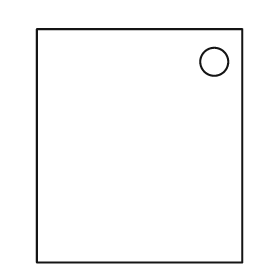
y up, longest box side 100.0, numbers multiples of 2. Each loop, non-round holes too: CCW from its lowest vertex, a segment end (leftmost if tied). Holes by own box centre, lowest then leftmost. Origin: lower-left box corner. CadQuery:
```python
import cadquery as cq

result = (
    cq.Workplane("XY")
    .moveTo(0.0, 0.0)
    .lineTo(88.0, 0.0)
    .lineTo(88.0, 100.0)
    .lineTo(0.0, 100.0)
    .close()
    .moveTo(76.0, 86.0)
    .circle(6.0)
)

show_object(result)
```